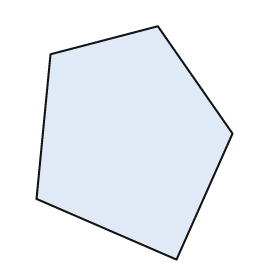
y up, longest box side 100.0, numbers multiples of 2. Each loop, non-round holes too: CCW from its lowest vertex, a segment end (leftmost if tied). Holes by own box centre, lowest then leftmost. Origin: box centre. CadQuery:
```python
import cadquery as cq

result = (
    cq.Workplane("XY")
    .moveTo(18.0, -50.0)
    .lineTo(42.0, 4.0)
    .lineTo(10.0, 50.0)
    .lineTo(-36.0, 38.0)
    .lineTo(-42.0, -24.0)
    .close()
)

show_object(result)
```